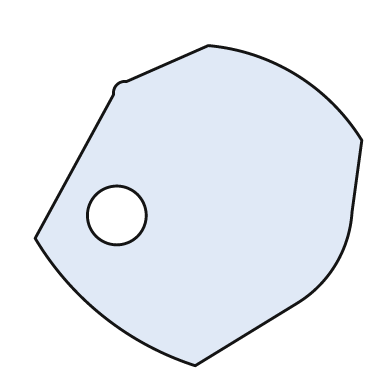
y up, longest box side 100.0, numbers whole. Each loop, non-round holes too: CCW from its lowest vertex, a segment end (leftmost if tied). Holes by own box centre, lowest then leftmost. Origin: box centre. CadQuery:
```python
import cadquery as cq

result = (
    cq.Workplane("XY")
    .moveTo(-1.0, -49.0)
    .lineTo(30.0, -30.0)
    .threePointArc((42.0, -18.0), (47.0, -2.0))
    .lineTo(50.0, 20.0)
    .threePointArc((30.0, 40.0), (3.0, 49.0))
    .lineTo(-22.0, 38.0)
    .threePointArc((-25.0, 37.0), (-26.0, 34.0))
    .lineTo(-50.0, -10.0)
    .threePointArc((-29.0, -34.0), (-1.0, -49.0))
    .close()
    .moveTo(-25.0, -3.0)
    .circle(9.0)
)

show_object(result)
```